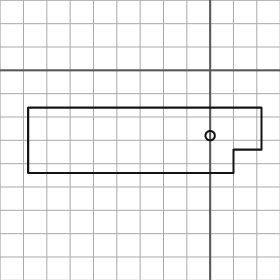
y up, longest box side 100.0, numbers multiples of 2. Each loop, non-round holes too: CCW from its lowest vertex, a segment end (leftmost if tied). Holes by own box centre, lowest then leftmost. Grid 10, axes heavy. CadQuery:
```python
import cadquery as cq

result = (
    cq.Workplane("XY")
    .moveTo(-78.0, -44.0)
    .lineTo(10.0, -44.0)
    .lineTo(10.0, -34.0)
    .lineTo(22.0, -34.0)
    .lineTo(22.0, -16.0)
    .lineTo(-78.0, -16.0)
    .close()
    .moveTo(0.0, -28.0)
    .circle(2.0)
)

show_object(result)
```